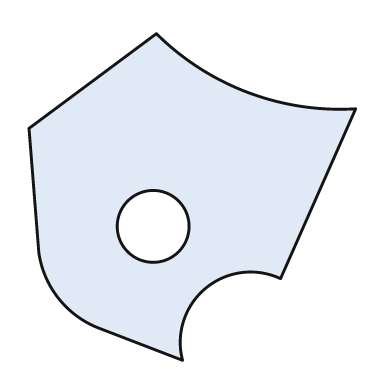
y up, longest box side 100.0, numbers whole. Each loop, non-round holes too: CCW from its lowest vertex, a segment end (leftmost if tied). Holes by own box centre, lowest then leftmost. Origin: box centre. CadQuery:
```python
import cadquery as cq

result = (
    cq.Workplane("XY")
    .moveTo(-3.0, -50.0)
    .threePointArc((4.0, -28.0), (27.0, -25.0))
    .lineTo(50.0, 27.0)
    .threePointArc((17.0, 32.0), (-11.0, 50.0))
    .lineTo(-50.0, 21.0)
    .lineTo(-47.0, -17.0)
    .threePointArc((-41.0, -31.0), (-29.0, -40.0))
    .close()
    .moveTo(-12.0, -9.0)
    .circle(11.0)
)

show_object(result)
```